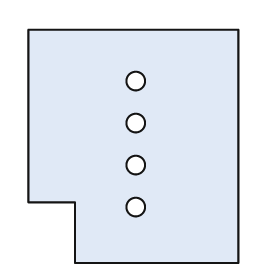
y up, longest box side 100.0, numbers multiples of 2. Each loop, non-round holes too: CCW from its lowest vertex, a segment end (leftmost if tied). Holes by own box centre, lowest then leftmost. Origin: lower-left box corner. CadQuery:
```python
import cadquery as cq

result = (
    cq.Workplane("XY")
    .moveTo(20.0, 0.0)
    .lineTo(90.0, 0.0)
    .lineTo(90.0, 100.0)
    .lineTo(0.0, 100.0)
    .lineTo(0.0, 26.0)
    .lineTo(20.0, 26.0)
    .close()
    .moveTo(46.0, 24.0)
    .circle(4.0)
    .moveTo(46.0, 42.0)
    .circle(4.0)
    .moveTo(46.0, 60.0)
    .circle(4.0)
    .moveTo(46.0, 78.0)
    .circle(4.0)
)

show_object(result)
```